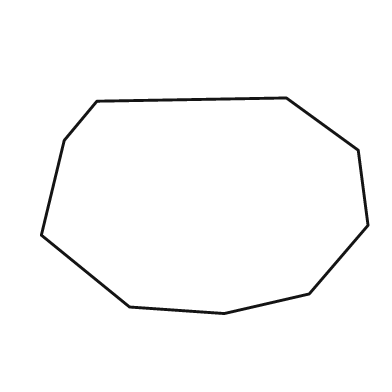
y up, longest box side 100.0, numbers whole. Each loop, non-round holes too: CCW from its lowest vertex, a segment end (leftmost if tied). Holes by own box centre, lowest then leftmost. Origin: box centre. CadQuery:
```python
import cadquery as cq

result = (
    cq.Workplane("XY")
    .moveTo(6.0, -33.0)
    .lineTo(32.0, -27.0)
    .lineTo(50.0, -6.0)
    .lineTo(47.0, 17.0)
    .lineTo(25.0, 33.0)
    .lineTo(-33.0, 32.0)
    .lineTo(-43.0, 20.0)
    .lineTo(-50.0, -9.0)
    .lineTo(-23.0, -31.0)
    .close()
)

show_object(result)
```